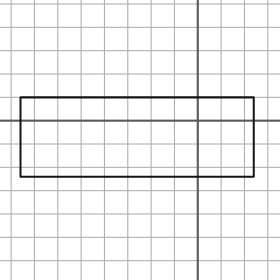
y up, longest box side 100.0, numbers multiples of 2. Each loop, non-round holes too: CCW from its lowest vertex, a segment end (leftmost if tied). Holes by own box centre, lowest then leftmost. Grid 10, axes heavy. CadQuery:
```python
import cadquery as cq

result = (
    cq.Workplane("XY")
    .moveTo(-76.0, -24.0)
    .lineTo(24.0, -24.0)
    .lineTo(24.0, 10.0)
    .lineTo(-76.0, 10.0)
    .close()
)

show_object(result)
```